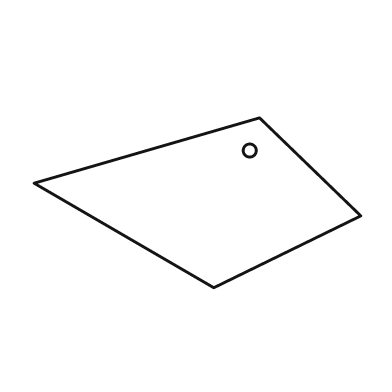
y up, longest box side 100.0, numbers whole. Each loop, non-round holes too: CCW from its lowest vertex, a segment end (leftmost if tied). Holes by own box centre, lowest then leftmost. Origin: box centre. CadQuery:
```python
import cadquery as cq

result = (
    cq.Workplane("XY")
    .moveTo(5.0, -26.0)
    .lineTo(50.0, -4.0)
    .lineTo(19.0, 26.0)
    .lineTo(-50.0, 6.0)
    .close()
    .moveTo(16.0, 16.0)
    .circle(2.0)
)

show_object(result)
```